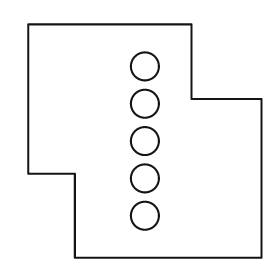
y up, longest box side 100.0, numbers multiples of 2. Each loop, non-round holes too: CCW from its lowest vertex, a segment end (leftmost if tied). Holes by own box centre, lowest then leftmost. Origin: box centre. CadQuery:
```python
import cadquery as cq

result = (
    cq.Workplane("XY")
    .moveTo(-30.0, -50.0)
    .lineTo(50.0, -50.0)
    .lineTo(50.0, 18.0)
    .lineTo(20.0, 18.0)
    .lineTo(20.0, 50.0)
    .lineTo(-50.0, 50.0)
    .lineTo(-50.0, -14.0)
    .lineTo(-30.0, -14.0)
    .close()
    .moveTo(0.0, -32.0)
    .circle(6.0)
    .moveTo(0.0, -16.0)
    .circle(6.0)
    .moveTo(0.0, 0.0)
    .circle(6.0)
    .moveTo(0.0, 16.0)
    .circle(6.0)
    .moveTo(0.0, 32.0)
    .circle(6.0)
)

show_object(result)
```